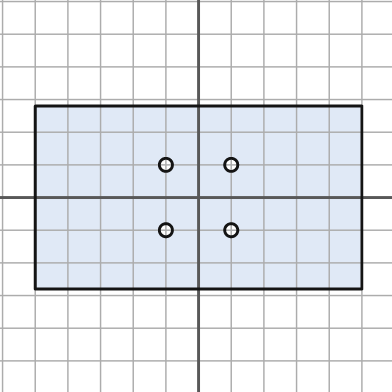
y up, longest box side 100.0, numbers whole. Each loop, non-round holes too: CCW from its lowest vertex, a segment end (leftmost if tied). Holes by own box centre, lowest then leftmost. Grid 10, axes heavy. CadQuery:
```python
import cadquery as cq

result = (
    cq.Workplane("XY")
    .moveTo(-50.0, -28.0)
    .lineTo(50.0, -28.0)
    .lineTo(50.0, 28.0)
    .lineTo(-50.0, 28.0)
    .close()
    .moveTo(-10.0, -10.0)
    .circle(2.0)
    .moveTo(10.0, -10.0)
    .circle(2.0)
    .moveTo(-10.0, 10.0)
    .circle(2.0)
    .moveTo(10.0, 10.0)
    .circle(2.0)
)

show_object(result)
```